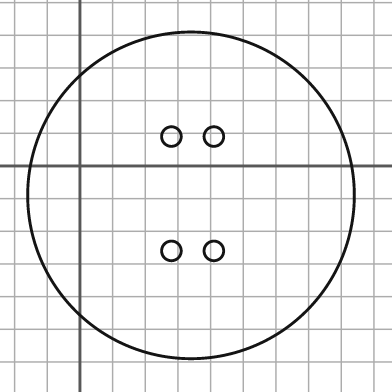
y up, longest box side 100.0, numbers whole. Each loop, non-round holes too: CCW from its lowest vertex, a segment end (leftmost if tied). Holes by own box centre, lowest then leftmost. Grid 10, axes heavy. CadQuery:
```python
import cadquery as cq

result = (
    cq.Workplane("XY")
    .moveTo(34.0, -9.0)
    .circle(50.0)
    .moveTo(28.0, -26.0)
    .circle(3.0)
    .moveTo(41.0, -26.0)
    .circle(3.0)
    .moveTo(28.0, 9.0)
    .circle(3.0)
    .moveTo(41.0, 9.0)
    .circle(3.0)
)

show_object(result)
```